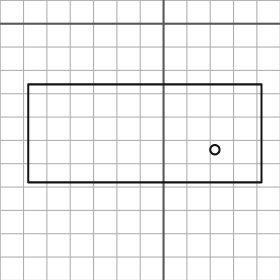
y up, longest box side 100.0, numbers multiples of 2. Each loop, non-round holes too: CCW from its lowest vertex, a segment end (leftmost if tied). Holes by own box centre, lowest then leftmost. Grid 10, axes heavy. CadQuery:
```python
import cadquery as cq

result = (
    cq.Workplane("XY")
    .moveTo(-58.0, -68.0)
    .lineTo(42.0, -68.0)
    .lineTo(42.0, -26.0)
    .lineTo(-58.0, -26.0)
    .close()
    .moveTo(22.0, -54.0)
    .circle(2.0)
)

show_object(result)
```